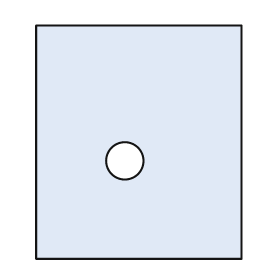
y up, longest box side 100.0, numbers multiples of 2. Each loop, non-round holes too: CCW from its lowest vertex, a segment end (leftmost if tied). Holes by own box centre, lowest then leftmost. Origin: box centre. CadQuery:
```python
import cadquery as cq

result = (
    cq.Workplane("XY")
    .moveTo(-44.0, -50.0)
    .lineTo(44.0, -50.0)
    .lineTo(44.0, 50.0)
    .lineTo(-44.0, 50.0)
    .close()
    .moveTo(-6.0, -8.0)
    .circle(8.0)
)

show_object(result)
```